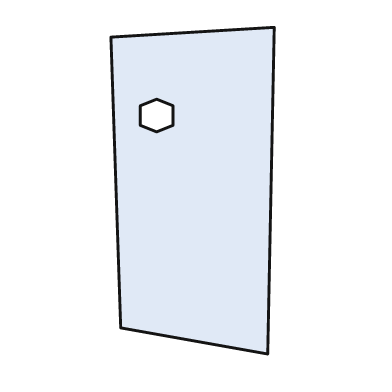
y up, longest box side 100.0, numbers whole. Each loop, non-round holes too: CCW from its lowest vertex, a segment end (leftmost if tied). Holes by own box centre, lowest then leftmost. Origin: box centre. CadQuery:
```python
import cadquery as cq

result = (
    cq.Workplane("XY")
    .moveTo(23.0, -50.0)
    .lineTo(25.0, 50.0)
    .lineTo(-25.0, 47.0)
    .lineTo(-22.0, -42.0)
    .close()
    .moveTo(-11.0, 18.0)
    .lineTo(-6.0, 20.0)
    .lineTo(-6.0, 26.0)
    .lineTo(-11.0, 28.0)
    .lineTo(-16.0, 26.0)
    .lineTo(-16.0, 20.0)
    .close()
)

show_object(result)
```